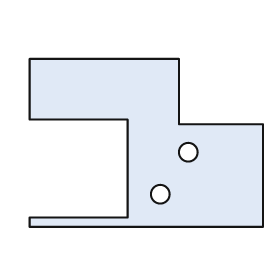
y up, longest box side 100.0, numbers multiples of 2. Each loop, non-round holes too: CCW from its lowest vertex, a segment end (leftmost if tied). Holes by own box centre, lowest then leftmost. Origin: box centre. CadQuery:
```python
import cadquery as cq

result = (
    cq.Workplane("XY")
    .moveTo(-50.0, -36.0)
    .lineTo(50.0, -36.0)
    .lineTo(50.0, 8.0)
    .lineTo(14.0, 8.0)
    .lineTo(14.0, 36.0)
    .lineTo(-50.0, 36.0)
    .lineTo(-50.0, 10.0)
    .lineTo(-8.0, 10.0)
    .lineTo(-8.0, -32.0)
    .lineTo(-50.0, -32.0)
    .close()
    .moveTo(6.0, -22.0)
    .circle(4.0)
    .moveTo(18.0, -4.0)
    .circle(4.0)
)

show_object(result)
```